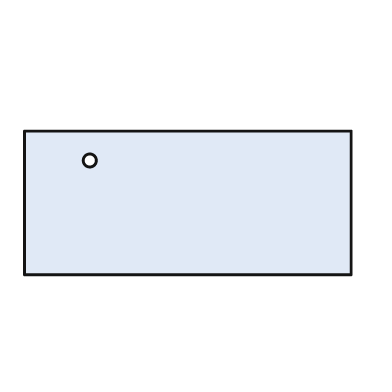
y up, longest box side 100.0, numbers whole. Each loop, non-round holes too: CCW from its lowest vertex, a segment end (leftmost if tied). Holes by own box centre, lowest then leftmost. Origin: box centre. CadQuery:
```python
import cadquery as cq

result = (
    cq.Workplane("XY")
    .moveTo(-50.0, -22.0)
    .lineTo(50.0, -22.0)
    .lineTo(50.0, 22.0)
    .lineTo(-50.0, 22.0)
    .close()
    .moveTo(-30.0, 13.0)
    .circle(2.0)
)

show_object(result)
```